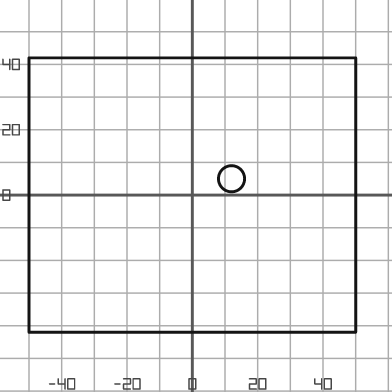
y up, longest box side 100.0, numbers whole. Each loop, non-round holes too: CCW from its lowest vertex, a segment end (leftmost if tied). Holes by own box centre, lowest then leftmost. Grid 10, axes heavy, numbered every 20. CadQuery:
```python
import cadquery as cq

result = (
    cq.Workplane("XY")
    .moveTo(-50.0, -42.0)
    .lineTo(50.0, -42.0)
    .lineTo(50.0, 42.0)
    .lineTo(-50.0, 42.0)
    .close()
    .moveTo(12.0, 5.0)
    .circle(4.0)
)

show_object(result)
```